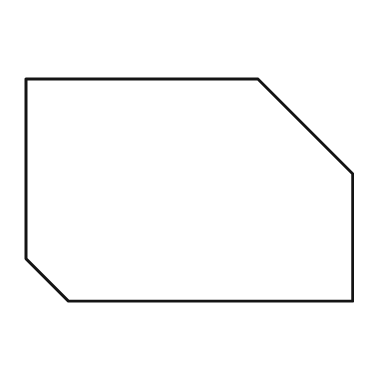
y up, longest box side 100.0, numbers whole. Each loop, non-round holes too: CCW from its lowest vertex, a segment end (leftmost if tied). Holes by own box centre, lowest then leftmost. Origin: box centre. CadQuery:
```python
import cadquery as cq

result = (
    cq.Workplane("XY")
    .moveTo(-37.0, -34.0)
    .lineTo(50.0, -34.0)
    .lineTo(50.0, 5.0)
    .lineTo(21.0, 34.0)
    .lineTo(-50.0, 34.0)
    .lineTo(-50.0, -21.0)
    .close()
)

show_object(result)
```